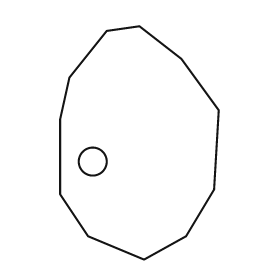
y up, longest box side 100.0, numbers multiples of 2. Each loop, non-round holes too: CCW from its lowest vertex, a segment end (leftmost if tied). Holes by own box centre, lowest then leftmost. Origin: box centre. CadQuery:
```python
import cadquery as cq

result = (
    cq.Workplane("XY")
    .moveTo(2.0, -50.0)
    .lineTo(20.0, -40.0)
    .lineTo(32.0, -20.0)
    .lineTo(34.0, 14.0)
    .lineTo(18.0, 36.0)
    .lineTo(0.0, 50.0)
    .lineTo(-14.0, 48.0)
    .lineTo(-30.0, 28.0)
    .lineTo(-34.0, 10.0)
    .lineTo(-34.0, -22.0)
    .lineTo(-22.0, -40.0)
    .close()
    .moveTo(-20.0, -8.0)
    .circle(6.0)
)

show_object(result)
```